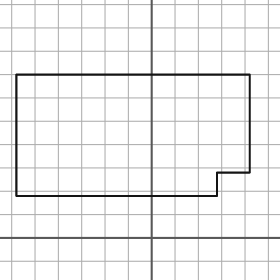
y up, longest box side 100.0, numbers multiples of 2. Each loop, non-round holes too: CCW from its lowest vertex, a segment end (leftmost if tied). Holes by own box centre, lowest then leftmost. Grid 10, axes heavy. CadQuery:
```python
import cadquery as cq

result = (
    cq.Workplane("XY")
    .moveTo(-58.0, 18.0)
    .lineTo(28.0, 18.0)
    .lineTo(28.0, 28.0)
    .lineTo(42.0, 28.0)
    .lineTo(42.0, 70.0)
    .lineTo(-58.0, 70.0)
    .close()
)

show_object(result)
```